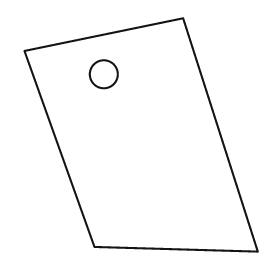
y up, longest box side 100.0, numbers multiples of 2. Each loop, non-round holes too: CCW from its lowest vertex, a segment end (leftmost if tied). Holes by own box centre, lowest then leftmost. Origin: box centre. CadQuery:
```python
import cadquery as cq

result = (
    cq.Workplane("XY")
    .moveTo(50.0, -50.0)
    .lineTo(18.0, 50.0)
    .lineTo(-50.0, 36.0)
    .lineTo(-20.0, -48.0)
    .close()
    .moveTo(-16.0, 26.0)
    .circle(6.0)
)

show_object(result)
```